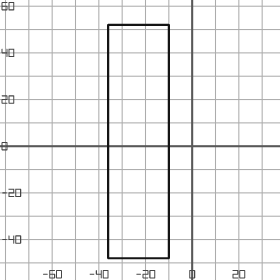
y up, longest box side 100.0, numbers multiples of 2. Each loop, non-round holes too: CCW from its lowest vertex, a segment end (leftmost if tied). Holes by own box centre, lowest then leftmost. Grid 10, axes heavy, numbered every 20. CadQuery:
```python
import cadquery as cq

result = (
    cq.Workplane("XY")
    .moveTo(-36.0, -48.0)
    .lineTo(-10.0, -48.0)
    .lineTo(-10.0, 52.0)
    .lineTo(-36.0, 52.0)
    .close()
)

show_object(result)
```